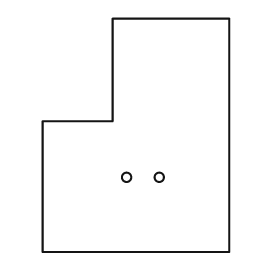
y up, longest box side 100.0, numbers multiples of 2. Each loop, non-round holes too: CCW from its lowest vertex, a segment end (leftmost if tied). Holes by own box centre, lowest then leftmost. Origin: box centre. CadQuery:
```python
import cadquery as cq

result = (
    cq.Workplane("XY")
    .moveTo(-40.0, -50.0)
    .lineTo(40.0, -50.0)
    .lineTo(40.0, 50.0)
    .lineTo(-10.0, 50.0)
    .lineTo(-10.0, 6.0)
    .lineTo(-40.0, 6.0)
    .close()
    .moveTo(-4.0, -18.0)
    .circle(2.0)
    .moveTo(10.0, -18.0)
    .circle(2.0)
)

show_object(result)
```